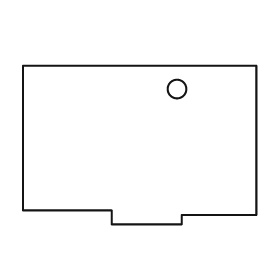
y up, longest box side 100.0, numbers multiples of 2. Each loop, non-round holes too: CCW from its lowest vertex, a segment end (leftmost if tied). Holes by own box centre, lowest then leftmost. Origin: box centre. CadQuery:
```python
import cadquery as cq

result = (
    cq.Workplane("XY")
    .moveTo(-12.0, -34.0)
    .lineTo(18.0, -34.0)
    .lineTo(18.0, -30.0)
    .lineTo(50.0, -30.0)
    .lineTo(50.0, 34.0)
    .lineTo(-50.0, 34.0)
    .lineTo(-50.0, -28.0)
    .lineTo(-12.0, -28.0)
    .close()
    .moveTo(16.0, 24.0)
    .circle(4.0)
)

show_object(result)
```